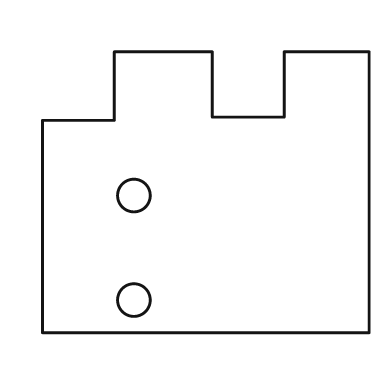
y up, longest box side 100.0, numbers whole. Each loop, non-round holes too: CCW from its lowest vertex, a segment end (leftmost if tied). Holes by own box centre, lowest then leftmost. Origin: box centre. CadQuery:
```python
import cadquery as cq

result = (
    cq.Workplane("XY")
    .moveTo(-50.0, -43.0)
    .lineTo(50.0, -43.0)
    .lineTo(50.0, 43.0)
    .lineTo(24.0, 43.0)
    .lineTo(24.0, 23.0)
    .lineTo(2.0, 23.0)
    .lineTo(2.0, 43.0)
    .lineTo(-28.0, 43.0)
    .lineTo(-28.0, 22.0)
    .lineTo(-50.0, 22.0)
    .close()
    .moveTo(-22.0, -33.0)
    .circle(5.0)
    .moveTo(-22.0, -1.0)
    .circle(5.0)
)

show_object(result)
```